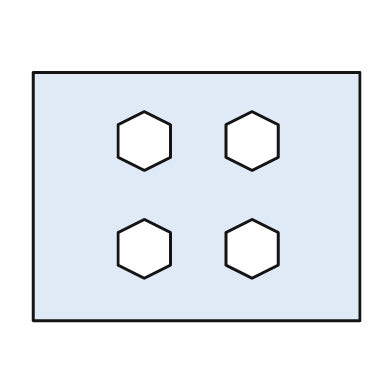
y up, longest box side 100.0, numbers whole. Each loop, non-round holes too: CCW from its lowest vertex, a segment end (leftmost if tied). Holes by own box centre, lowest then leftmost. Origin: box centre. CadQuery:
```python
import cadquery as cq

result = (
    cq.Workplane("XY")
    .moveTo(-50.0, -38.0)
    .lineTo(50.0, -38.0)
    .lineTo(50.0, 38.0)
    .lineTo(-50.0, 38.0)
    .close()
    .moveTo(-16.0, -25.0)
    .lineTo(-8.0, -21.0)
    .lineTo(-8.0, -11.0)
    .lineTo(-16.0, -7.0)
    .lineTo(-24.0, -11.0)
    .lineTo(-24.0, -21.0)
    .close()
    .moveTo(17.0, -25.0)
    .lineTo(25.0, -21.0)
    .lineTo(25.0, -11.0)
    .lineTo(17.0, -7.0)
    .lineTo(9.0, -11.0)
    .lineTo(9.0, -21.0)
    .close()
    .moveTo(-16.0, 8.0)
    .lineTo(-8.0, 12.0)
    .lineTo(-8.0, 22.0)
    .lineTo(-16.0, 26.0)
    .lineTo(-24.0, 22.0)
    .lineTo(-24.0, 12.0)
    .close()
    .moveTo(17.0, 8.0)
    .lineTo(25.0, 12.0)
    .lineTo(25.0, 22.0)
    .lineTo(17.0, 26.0)
    .lineTo(9.0, 22.0)
    .lineTo(9.0, 12.0)
    .close()
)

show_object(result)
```